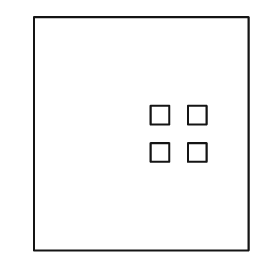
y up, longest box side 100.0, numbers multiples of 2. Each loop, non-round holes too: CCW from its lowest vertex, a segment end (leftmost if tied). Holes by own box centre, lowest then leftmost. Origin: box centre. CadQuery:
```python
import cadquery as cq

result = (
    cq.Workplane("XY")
    .moveTo(-46.0, -50.0)
    .lineTo(46.0, -50.0)
    .lineTo(46.0, 50.0)
    .lineTo(-46.0, 50.0)
    .close()
    .moveTo(4.0, -12.0)
    .lineTo(12.0, -12.0)
    .lineTo(12.0, -4.0)
    .lineTo(4.0, -4.0)
    .close()
    .moveTo(20.0, -12.0)
    .lineTo(28.0, -12.0)
    .lineTo(28.0, -4.0)
    .lineTo(20.0, -4.0)
    .close()
    .moveTo(4.0, 4.0)
    .lineTo(12.0, 4.0)
    .lineTo(12.0, 12.0)
    .lineTo(4.0, 12.0)
    .close()
    .moveTo(20.0, 4.0)
    .lineTo(28.0, 4.0)
    .lineTo(28.0, 12.0)
    .lineTo(20.0, 12.0)
    .close()
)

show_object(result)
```